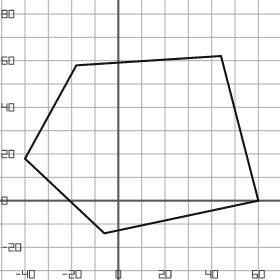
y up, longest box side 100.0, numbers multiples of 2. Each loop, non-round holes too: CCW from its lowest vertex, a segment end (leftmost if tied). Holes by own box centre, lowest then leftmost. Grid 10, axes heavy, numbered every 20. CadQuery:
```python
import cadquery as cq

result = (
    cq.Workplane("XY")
    .moveTo(-6.0, -14.0)
    .lineTo(60.0, 0.0)
    .lineTo(44.0, 62.0)
    .lineTo(-18.0, 58.0)
    .lineTo(-40.0, 18.0)
    .close()
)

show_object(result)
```